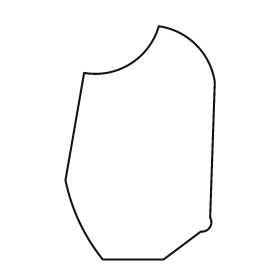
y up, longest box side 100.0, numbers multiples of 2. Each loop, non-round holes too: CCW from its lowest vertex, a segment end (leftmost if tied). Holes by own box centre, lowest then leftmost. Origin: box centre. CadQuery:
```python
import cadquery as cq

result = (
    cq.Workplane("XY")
    .moveTo(-16.0, -50.0)
    .lineTo(10.0, -50.0)
    .lineTo(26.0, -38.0)
    .threePointArc((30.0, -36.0), (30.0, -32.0))
    .lineTo(32.0, 26.0)
    .threePointArc((24.0, 42.0), (8.0, 50.0))
    .threePointArc((-4.0, 34.0), (-24.0, 30.0))
    .lineTo(-32.0, -16.0)
    .threePointArc((-26.0, -34.0), (-16.0, -50.0))
    .close()
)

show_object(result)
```